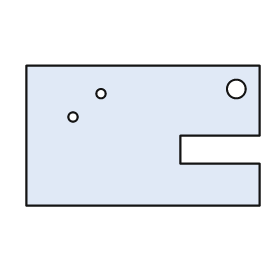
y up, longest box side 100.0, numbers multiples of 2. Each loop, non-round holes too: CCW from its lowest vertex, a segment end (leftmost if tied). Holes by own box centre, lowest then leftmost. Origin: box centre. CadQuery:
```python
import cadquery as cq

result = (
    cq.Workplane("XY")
    .moveTo(-50.0, -30.0)
    .lineTo(50.0, -30.0)
    .lineTo(50.0, -12.0)
    .lineTo(16.0, -12.0)
    .lineTo(16.0, 0.0)
    .lineTo(50.0, 0.0)
    .lineTo(50.0, 30.0)
    .lineTo(-50.0, 30.0)
    .close()
    .moveTo(-30.0, 8.0)
    .circle(2.0)
    .moveTo(-18.0, 18.0)
    .circle(2.0)
    .moveTo(40.0, 20.0)
    .circle(4.0)
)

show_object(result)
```